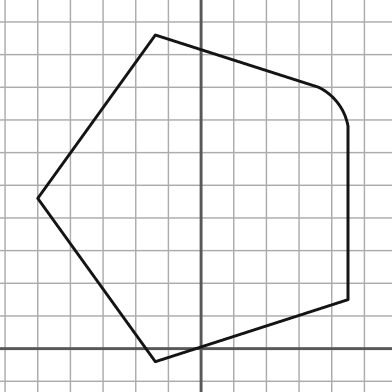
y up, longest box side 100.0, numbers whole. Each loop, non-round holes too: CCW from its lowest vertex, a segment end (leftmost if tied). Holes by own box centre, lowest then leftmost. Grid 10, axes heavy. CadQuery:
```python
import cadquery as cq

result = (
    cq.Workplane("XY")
    .moveTo(-14.0, -4.0)
    .lineTo(45.0, 15.0)
    .lineTo(45.0, 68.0)
    .threePointArc((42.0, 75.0), (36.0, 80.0))
    .lineTo(-14.0, 96.0)
    .lineTo(-50.0, 46.0)
    .close()
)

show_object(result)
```